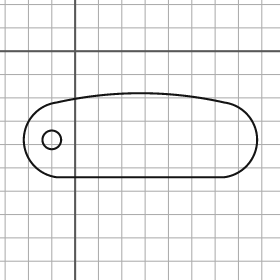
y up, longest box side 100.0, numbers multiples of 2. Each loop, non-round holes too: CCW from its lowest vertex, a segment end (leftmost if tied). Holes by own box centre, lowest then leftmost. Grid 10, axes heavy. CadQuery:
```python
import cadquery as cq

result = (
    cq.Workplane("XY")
    .moveTo(-8.0, -54.0)
    .lineTo(64.0, -54.0)
    .threePointArc((78.0, -38.0), (64.0, -22.0))
    .threePointArc((28.0, -18.0), (-8.0, -22.0))
    .threePointArc((-22.0, -38.0), (-8.0, -54.0))
    .close()
    .moveTo(-10.0, -38.0)
    .circle(4.0)
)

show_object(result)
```